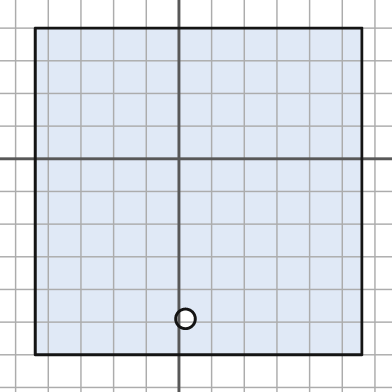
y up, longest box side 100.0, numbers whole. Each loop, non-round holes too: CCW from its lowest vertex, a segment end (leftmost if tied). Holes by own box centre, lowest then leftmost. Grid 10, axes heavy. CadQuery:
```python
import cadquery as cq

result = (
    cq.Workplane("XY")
    .moveTo(-44.0, -60.0)
    .lineTo(56.0, -60.0)
    .lineTo(56.0, 40.0)
    .lineTo(-44.0, 40.0)
    .close()
    .moveTo(2.0, -49.0)
    .circle(3.0)
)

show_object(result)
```